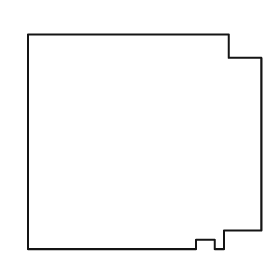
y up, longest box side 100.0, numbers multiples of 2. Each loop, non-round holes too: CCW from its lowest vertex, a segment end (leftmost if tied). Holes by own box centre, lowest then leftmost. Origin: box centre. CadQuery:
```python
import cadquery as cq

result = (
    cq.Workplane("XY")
    .moveTo(-50.0, -46.0)
    .lineTo(22.0, -46.0)
    .lineTo(22.0, -42.0)
    .lineTo(30.0, -42.0)
    .lineTo(30.0, -46.0)
    .lineTo(34.0, -46.0)
    .lineTo(34.0, -38.0)
    .lineTo(50.0, -38.0)
    .lineTo(50.0, 36.0)
    .lineTo(36.0, 36.0)
    .lineTo(36.0, 46.0)
    .lineTo(-50.0, 46.0)
    .close()
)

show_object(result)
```